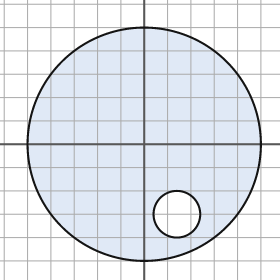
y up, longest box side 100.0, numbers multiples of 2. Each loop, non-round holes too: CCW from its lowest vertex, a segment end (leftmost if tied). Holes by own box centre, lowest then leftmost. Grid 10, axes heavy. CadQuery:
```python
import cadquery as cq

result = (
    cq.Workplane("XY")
    .moveTo(0.0, 0.0)
    .circle(50.0)
    .moveTo(14.0, -30.0)
    .circle(10.0)
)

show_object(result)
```